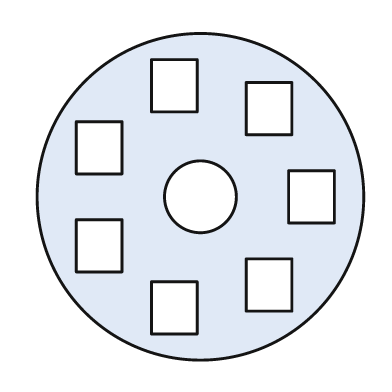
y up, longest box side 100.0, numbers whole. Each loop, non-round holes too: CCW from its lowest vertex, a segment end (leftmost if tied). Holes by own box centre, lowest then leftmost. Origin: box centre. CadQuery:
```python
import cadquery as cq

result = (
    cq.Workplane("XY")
    .moveTo(0.0, 0.0)
    .circle(50.0)
    .moveTo(-15.0, -42.0)
    .lineTo(-1.0, -42.0)
    .lineTo(-1.0, -26.0)
    .lineTo(-15.0, -26.0)
    .close()
    .moveTo(14.0, -35.0)
    .lineTo(28.0, -35.0)
    .lineTo(28.0, -19.0)
    .lineTo(14.0, -19.0)
    .close()
    .moveTo(-38.0, -23.0)
    .lineTo(-24.0, -23.0)
    .lineTo(-24.0, -7.0)
    .lineTo(-38.0, -7.0)
    .close()
    .moveTo(0.0, 0.0)
    .circle(11.0)
    .moveTo(27.0, -8.0)
    .lineTo(41.0, -8.0)
    .lineTo(41.0, 8.0)
    .lineTo(27.0, 8.0)
    .close()
    .moveTo(-38.0, 7.0)
    .lineTo(-24.0, 7.0)
    .lineTo(-24.0, 23.0)
    .lineTo(-38.0, 23.0)
    .close()
    .moveTo(14.0, 19.0)
    .lineTo(28.0, 19.0)
    .lineTo(28.0, 35.0)
    .lineTo(14.0, 35.0)
    .close()
    .moveTo(-15.0, 26.0)
    .lineTo(-1.0, 26.0)
    .lineTo(-1.0, 42.0)
    .lineTo(-15.0, 42.0)
    .close()
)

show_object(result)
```